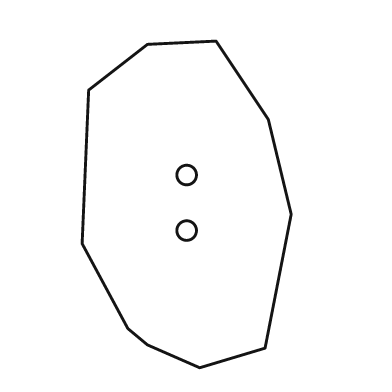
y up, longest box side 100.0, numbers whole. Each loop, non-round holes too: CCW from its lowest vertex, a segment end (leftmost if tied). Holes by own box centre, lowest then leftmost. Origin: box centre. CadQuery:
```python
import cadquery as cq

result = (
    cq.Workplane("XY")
    .moveTo(4.0, -50.0)
    .lineTo(24.0, -44.0)
    .lineTo(32.0, -3.0)
    .lineTo(25.0, 26.0)
    .lineTo(9.0, 50.0)
    .lineTo(-12.0, 49.0)
    .lineTo(-30.0, 35.0)
    .lineTo(-32.0, -12.0)
    .lineTo(-18.0, -38.0)
    .lineTo(-12.0, -43.0)
    .close()
    .moveTo(0.0, -8.0)
    .circle(3.0)
    .moveTo(0.0, 9.0)
    .circle(3.0)
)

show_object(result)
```